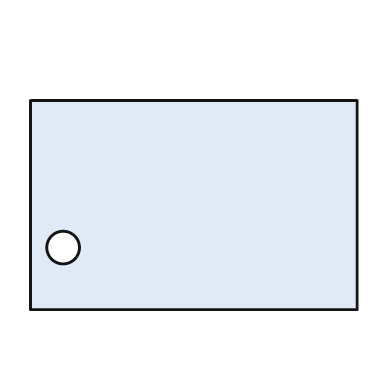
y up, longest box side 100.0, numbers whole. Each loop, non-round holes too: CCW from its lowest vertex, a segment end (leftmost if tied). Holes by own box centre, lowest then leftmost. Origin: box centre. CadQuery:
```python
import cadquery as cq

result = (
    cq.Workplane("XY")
    .moveTo(-50.0, -32.0)
    .lineTo(50.0, -32.0)
    .lineTo(50.0, 32.0)
    .lineTo(-50.0, 32.0)
    .close()
    .moveTo(-40.0, -13.0)
    .circle(5.0)
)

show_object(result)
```